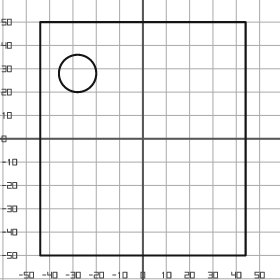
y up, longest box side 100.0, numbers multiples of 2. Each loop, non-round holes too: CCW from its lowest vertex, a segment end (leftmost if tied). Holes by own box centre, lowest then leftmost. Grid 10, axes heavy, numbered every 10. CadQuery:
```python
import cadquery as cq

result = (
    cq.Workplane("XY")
    .moveTo(-44.0, -50.0)
    .lineTo(44.0, -50.0)
    .lineTo(44.0, 50.0)
    .lineTo(-44.0, 50.0)
    .close()
    .moveTo(-28.0, 28.0)
    .circle(8.0)
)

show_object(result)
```